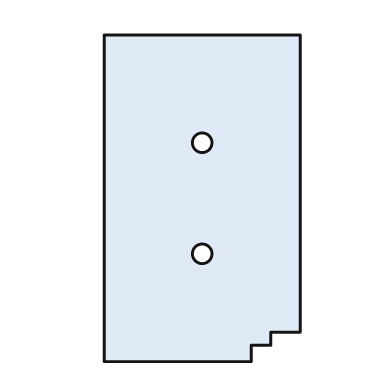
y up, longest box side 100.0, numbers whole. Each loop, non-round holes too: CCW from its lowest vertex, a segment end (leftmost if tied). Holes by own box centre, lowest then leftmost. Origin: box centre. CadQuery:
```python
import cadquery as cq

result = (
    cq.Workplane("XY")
    .moveTo(-30.0, -50.0)
    .lineTo(15.0, -50.0)
    .lineTo(15.0, -45.0)
    .lineTo(21.0, -45.0)
    .lineTo(21.0, -41.0)
    .lineTo(30.0, -41.0)
    .lineTo(30.0, 50.0)
    .lineTo(-30.0, 50.0)
    .close()
    .moveTo(0.0, -17.0)
    .circle(3.0)
    .moveTo(0.0, 17.0)
    .circle(3.0)
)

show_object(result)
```